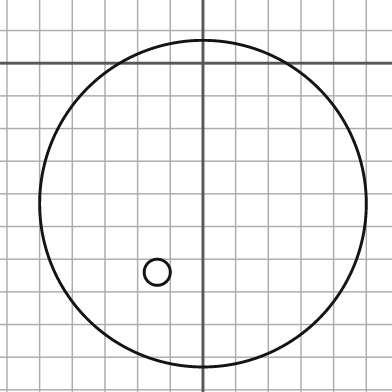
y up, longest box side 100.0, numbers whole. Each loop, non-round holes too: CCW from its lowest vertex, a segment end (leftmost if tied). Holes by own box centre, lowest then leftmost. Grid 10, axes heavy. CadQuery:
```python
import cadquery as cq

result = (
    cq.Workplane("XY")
    .moveTo(0.0, -43.0)
    .circle(50.0)
    .moveTo(-14.0, -64.0)
    .circle(4.0)
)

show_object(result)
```